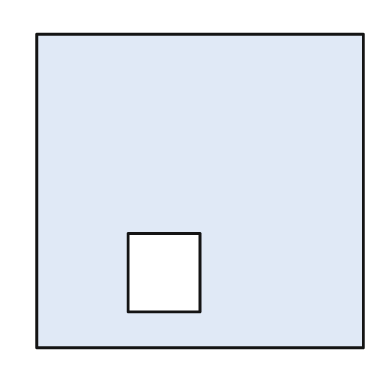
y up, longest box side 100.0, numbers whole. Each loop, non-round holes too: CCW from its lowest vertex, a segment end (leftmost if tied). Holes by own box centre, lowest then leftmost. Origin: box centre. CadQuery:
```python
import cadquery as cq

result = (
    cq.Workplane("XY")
    .moveTo(-50.0, -48.0)
    .lineTo(50.0, -48.0)
    .lineTo(50.0, 48.0)
    .lineTo(-50.0, 48.0)
    .close()
    .moveTo(-22.0, -37.0)
    .lineTo(0.0, -37.0)
    .lineTo(0.0, -13.0)
    .lineTo(-22.0, -13.0)
    .close()
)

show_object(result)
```